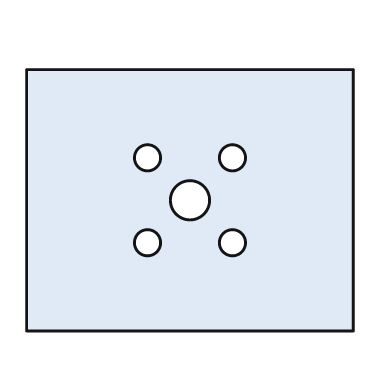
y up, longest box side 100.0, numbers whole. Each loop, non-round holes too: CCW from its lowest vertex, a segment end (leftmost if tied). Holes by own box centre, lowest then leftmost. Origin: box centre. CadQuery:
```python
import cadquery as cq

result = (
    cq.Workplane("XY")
    .moveTo(-50.0, -40.0)
    .lineTo(50.0, -40.0)
    .lineTo(50.0, 40.0)
    .lineTo(-50.0, 40.0)
    .close()
    .moveTo(-13.0, -13.0)
    .circle(4.0)
    .moveTo(13.0, -13.0)
    .circle(4.0)
    .moveTo(0.0, 0.0)
    .circle(6.0)
    .moveTo(-13.0, 13.0)
    .circle(4.0)
    .moveTo(13.0, 13.0)
    .circle(4.0)
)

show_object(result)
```